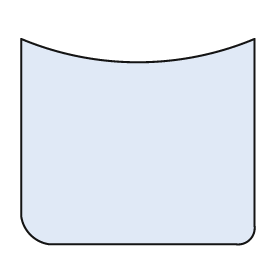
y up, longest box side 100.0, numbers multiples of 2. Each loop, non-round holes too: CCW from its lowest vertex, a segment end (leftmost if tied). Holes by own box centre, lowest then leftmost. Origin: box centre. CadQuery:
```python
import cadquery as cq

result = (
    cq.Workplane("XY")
    .moveTo(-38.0, -44.0)
    .lineTo(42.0, -44.0)
    .threePointArc((48.0, -42.0), (50.0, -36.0))
    .lineTo(50.0, 44.0)
    .threePointArc((0.0, 34.0), (-50.0, 44.0))
    .lineTo(-50.0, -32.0)
    .threePointArc((-46.0, -40.0), (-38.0, -44.0))
    .close()
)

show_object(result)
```